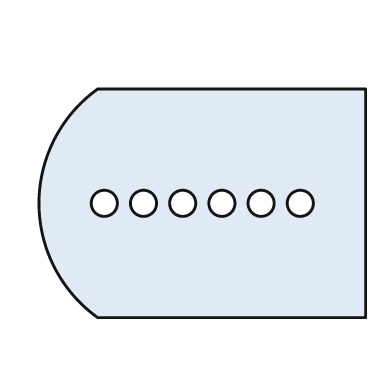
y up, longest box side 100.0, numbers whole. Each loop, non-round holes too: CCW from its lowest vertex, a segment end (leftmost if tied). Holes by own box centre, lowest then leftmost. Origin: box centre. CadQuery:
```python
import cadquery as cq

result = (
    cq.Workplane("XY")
    .moveTo(-32.0, -35.0)
    .lineTo(50.0, -35.0)
    .lineTo(50.0, 35.0)
    .lineTo(-32.0, 35.0)
    .threePointArc((-50.0, 0.0), (-32.0, -35.0))
    .close()
    .moveTo(-30.0, 0.0)
    .circle(4.0)
    .moveTo(-18.0, 0.0)
    .circle(4.0)
    .moveTo(-6.0, 0.0)
    .circle(4.0)
    .moveTo(6.0, 0.0)
    .circle(4.0)
    .moveTo(18.0, 0.0)
    .circle(4.0)
    .moveTo(30.0, 0.0)
    .circle(4.0)
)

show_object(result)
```